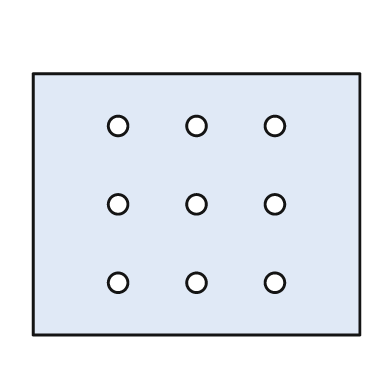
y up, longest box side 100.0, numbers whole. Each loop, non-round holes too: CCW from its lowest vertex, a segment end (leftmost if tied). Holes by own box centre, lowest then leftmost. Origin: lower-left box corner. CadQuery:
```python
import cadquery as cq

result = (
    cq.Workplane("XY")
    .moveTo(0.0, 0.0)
    .lineTo(100.0, 0.0)
    .lineTo(100.0, 80.0)
    .lineTo(0.0, 80.0)
    .close()
    .moveTo(26.0, 16.0)
    .circle(3.0)
    .moveTo(50.0, 16.0)
    .circle(3.0)
    .moveTo(74.0, 16.0)
    .circle(3.0)
    .moveTo(26.0, 40.0)
    .circle(3.0)
    .moveTo(50.0, 40.0)
    .circle(3.0)
    .moveTo(74.0, 40.0)
    .circle(3.0)
    .moveTo(26.0, 64.0)
    .circle(3.0)
    .moveTo(50.0, 64.0)
    .circle(3.0)
    .moveTo(74.0, 64.0)
    .circle(3.0)
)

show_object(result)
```